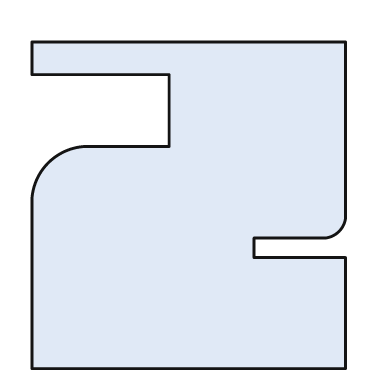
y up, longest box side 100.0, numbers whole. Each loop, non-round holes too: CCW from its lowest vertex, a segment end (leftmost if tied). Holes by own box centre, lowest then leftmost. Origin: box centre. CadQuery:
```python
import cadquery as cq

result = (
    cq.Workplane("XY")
    .moveTo(-48.0, -50.0)
    .lineTo(48.0, -50.0)
    .lineTo(48.0, -16.0)
    .lineTo(20.0, -16.0)
    .lineTo(20.0, -10.0)
    .lineTo(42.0, -10.0)
    .threePointArc((46.0, -8.0), (48.0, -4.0))
    .lineTo(48.0, 50.0)
    .lineTo(-48.0, 50.0)
    .lineTo(-48.0, 40.0)
    .lineTo(-6.0, 40.0)
    .lineTo(-6.0, 18.0)
    .lineTo(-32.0, 18.0)
    .threePointArc((-43.0, 13.0), (-48.0, 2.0))
    .close()
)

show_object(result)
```